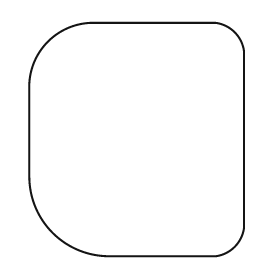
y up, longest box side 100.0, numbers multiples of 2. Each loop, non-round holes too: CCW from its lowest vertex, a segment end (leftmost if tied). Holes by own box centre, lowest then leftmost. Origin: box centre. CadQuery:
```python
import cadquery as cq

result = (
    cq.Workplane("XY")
    .moveTo(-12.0, -50.0)
    .lineTo(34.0, -50.0)
    .threePointArc((42.0, -46.0), (46.0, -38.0))
    .lineTo(46.0, 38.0)
    .threePointArc((42.0, 46.0), (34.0, 50.0))
    .lineTo(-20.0, 50.0)
    .threePointArc((-38.0, 42.0), (-46.0, 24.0))
    .lineTo(-46.0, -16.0)
    .threePointArc((-36.0, -40.0), (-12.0, -50.0))
    .close()
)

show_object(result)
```